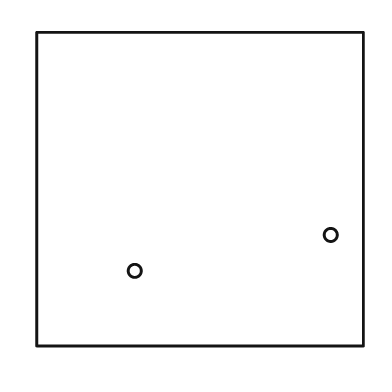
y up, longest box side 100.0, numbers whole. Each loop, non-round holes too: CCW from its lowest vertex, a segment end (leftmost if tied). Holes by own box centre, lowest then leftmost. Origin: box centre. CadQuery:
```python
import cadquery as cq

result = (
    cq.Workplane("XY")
    .moveTo(-50.0, -48.0)
    .lineTo(50.0, -48.0)
    .lineTo(50.0, 48.0)
    .lineTo(-50.0, 48.0)
    .close()
    .moveTo(-20.0, -25.0)
    .circle(2.0)
    .moveTo(40.0, -14.0)
    .circle(2.0)
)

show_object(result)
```